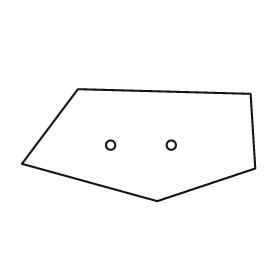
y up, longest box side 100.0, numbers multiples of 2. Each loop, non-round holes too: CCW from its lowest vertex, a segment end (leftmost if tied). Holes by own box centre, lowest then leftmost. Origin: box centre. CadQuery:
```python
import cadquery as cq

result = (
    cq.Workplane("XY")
    .moveTo(8.0, -24.0)
    .lineTo(50.0, -10.0)
    .lineTo(48.0, 22.0)
    .lineTo(-26.0, 24.0)
    .lineTo(-50.0, -8.0)
    .close()
    .moveTo(-12.0, 0.0)
    .circle(2.0)
    .moveTo(14.0, 0.0)
    .circle(2.0)
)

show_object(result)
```